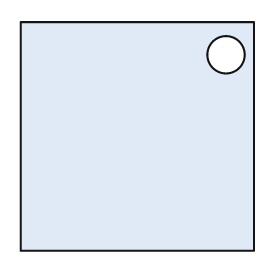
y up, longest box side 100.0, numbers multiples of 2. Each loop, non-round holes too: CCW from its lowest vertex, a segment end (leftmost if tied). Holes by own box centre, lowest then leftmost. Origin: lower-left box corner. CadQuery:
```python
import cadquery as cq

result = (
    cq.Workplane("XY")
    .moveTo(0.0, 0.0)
    .lineTo(100.0, 0.0)
    .lineTo(100.0, 98.0)
    .lineTo(0.0, 98.0)
    .close()
    .moveTo(88.0, 84.0)
    .circle(8.0)
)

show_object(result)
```